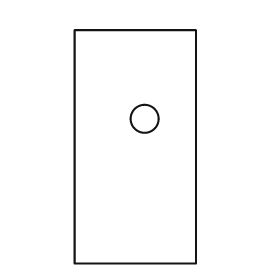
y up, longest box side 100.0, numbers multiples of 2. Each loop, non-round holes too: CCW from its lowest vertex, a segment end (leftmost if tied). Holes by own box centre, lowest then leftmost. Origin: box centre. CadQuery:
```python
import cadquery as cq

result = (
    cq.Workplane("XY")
    .moveTo(-26.0, -50.0)
    .lineTo(26.0, -50.0)
    .lineTo(26.0, 50.0)
    .lineTo(-26.0, 50.0)
    .close()
    .moveTo(4.0, 12.0)
    .circle(6.0)
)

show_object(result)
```